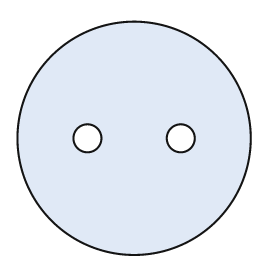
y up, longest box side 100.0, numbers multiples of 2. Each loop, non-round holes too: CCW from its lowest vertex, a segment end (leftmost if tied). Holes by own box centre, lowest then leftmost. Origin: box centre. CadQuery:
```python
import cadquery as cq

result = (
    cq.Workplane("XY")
    .moveTo(0.0, 0.0)
    .circle(50.0)
    .moveTo(-20.0, 0.0)
    .circle(6.0)
    .moveTo(20.0, 0.0)
    .circle(6.0)
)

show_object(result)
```